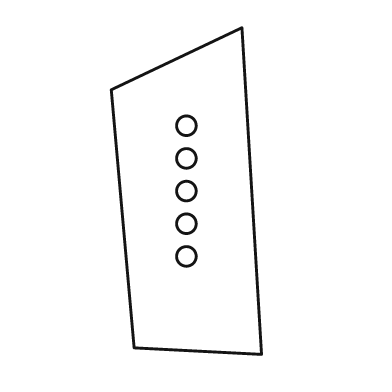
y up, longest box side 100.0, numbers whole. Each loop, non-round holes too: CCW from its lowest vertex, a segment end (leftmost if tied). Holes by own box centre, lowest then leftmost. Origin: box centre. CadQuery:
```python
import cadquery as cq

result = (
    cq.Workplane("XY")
    .moveTo(23.0, -50.0)
    .lineTo(17.0, 50.0)
    .lineTo(-23.0, 31.0)
    .lineTo(-16.0, -48.0)
    .close()
    .moveTo(0.0, -20.0)
    .circle(3.0)
    .moveTo(0.0, -10.0)
    .circle(3.0)
    .moveTo(0.0, 0.0)
    .circle(3.0)
    .moveTo(0.0, 10.0)
    .circle(3.0)
    .moveTo(0.0, 20.0)
    .circle(3.0)
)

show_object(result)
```